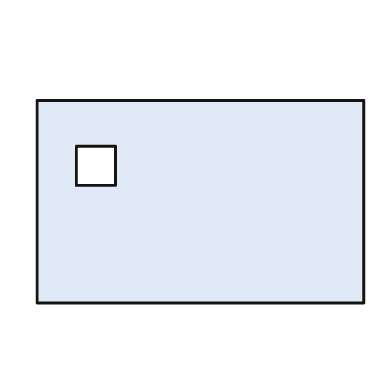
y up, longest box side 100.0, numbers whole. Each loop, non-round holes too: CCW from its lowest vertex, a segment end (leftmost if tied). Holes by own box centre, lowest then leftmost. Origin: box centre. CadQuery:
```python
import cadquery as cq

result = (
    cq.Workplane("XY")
    .moveTo(-50.0, -31.0)
    .lineTo(50.0, -31.0)
    .lineTo(50.0, 31.0)
    .lineTo(-50.0, 31.0)
    .close()
    .moveTo(-38.0, 5.0)
    .lineTo(-26.0, 5.0)
    .lineTo(-26.0, 17.0)
    .lineTo(-38.0, 17.0)
    .close()
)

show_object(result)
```